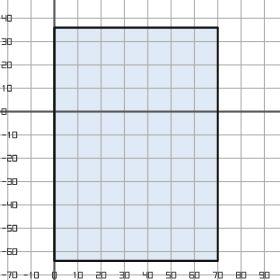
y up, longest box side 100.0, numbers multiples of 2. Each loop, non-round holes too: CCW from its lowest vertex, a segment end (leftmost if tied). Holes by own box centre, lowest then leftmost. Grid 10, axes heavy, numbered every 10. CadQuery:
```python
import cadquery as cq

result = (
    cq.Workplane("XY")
    .moveTo(0.0, -64.0)
    .lineTo(70.0, -64.0)
    .lineTo(70.0, 36.0)
    .lineTo(0.0, 36.0)
    .close()
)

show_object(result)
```